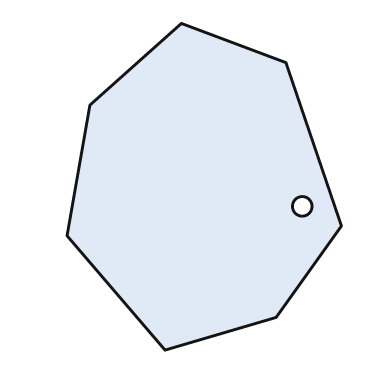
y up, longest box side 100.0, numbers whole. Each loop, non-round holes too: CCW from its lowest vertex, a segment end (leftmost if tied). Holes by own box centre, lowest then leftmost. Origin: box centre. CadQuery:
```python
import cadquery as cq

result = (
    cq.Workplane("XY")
    .moveTo(-12.0, -50.0)
    .lineTo(22.0, -40.0)
    .lineTo(42.0, -12.0)
    .lineTo(25.0, 38.0)
    .lineTo(-7.0, 50.0)
    .lineTo(-35.0, 25.0)
    .lineTo(-42.0, -15.0)
    .close()
    .moveTo(30.0, -6.0)
    .circle(3.0)
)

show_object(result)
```